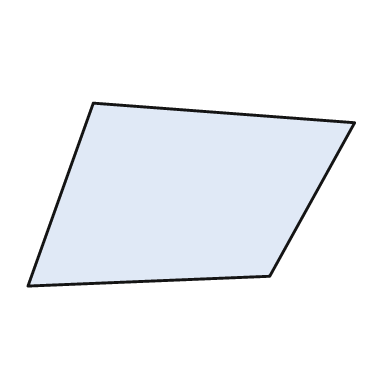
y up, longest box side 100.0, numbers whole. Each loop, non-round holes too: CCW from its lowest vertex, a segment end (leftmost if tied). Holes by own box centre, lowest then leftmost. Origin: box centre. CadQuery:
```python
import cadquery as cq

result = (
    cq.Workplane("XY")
    .moveTo(-50.0, -28.0)
    .lineTo(24.0, -25.0)
    .lineTo(50.0, 22.0)
    .lineTo(-30.0, 28.0)
    .close()
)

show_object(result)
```